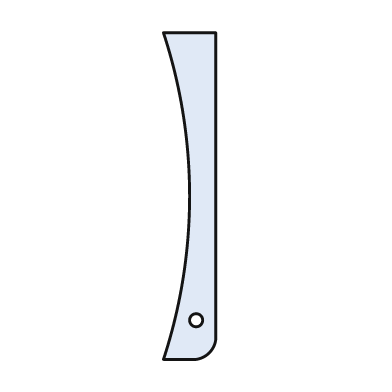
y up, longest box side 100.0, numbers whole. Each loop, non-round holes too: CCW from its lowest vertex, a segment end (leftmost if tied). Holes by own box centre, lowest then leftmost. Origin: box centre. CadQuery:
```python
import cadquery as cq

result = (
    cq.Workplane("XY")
    .moveTo(-8.0, -50.0)
    .lineTo(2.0, -50.0)
    .threePointArc((6.0, -48.0), (8.0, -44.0))
    .lineTo(8.0, 50.0)
    .lineTo(-8.0, 50.0)
    .threePointArc((0.0, 0.0), (-8.0, -50.0))
    .close()
    .moveTo(2.0, -38.0)
    .circle(2.0)
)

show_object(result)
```